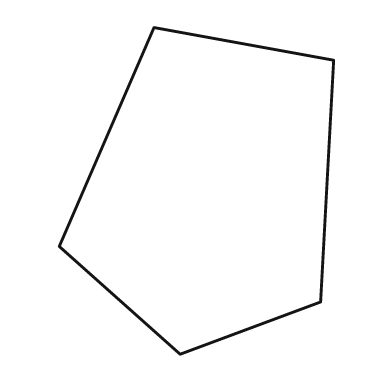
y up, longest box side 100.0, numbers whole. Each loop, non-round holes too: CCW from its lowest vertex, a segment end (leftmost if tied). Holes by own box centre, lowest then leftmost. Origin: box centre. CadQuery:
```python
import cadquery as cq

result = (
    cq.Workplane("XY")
    .moveTo(-5.0, -50.0)
    .lineTo(38.0, -34.0)
    .lineTo(42.0, 40.0)
    .lineTo(-13.0, 50.0)
    .lineTo(-42.0, -17.0)
    .close()
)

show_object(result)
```